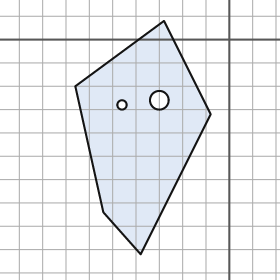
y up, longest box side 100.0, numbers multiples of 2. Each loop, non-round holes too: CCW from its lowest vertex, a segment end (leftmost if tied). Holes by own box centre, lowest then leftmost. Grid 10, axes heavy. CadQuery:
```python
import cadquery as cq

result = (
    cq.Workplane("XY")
    .moveTo(-38.0, -92.0)
    .lineTo(-8.0, -32.0)
    .lineTo(-28.0, 8.0)
    .lineTo(-66.0, -20.0)
    .lineTo(-54.0, -74.0)
    .close()
    .moveTo(-46.0, -28.0)
    .circle(2.0)
    .moveTo(-30.0, -26.0)
    .circle(4.0)
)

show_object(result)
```